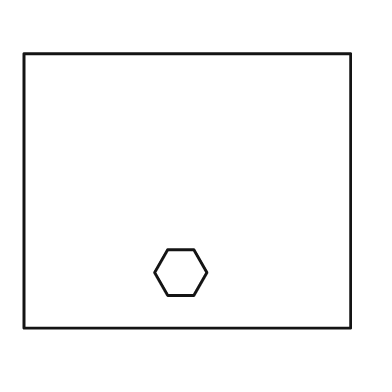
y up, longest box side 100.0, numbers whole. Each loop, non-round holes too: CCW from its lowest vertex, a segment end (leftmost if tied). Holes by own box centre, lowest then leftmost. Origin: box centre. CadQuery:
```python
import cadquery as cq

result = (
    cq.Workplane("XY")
    .moveTo(-50.0, -42.0)
    .lineTo(50.0, -42.0)
    .lineTo(50.0, 42.0)
    .lineTo(-50.0, 42.0)
    .close()
    .moveTo(-6.0, -32.0)
    .lineTo(2.0, -32.0)
    .lineTo(6.0, -25.0)
    .lineTo(2.0, -18.0)
    .lineTo(-6.0, -18.0)
    .lineTo(-10.0, -25.0)
    .close()
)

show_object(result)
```